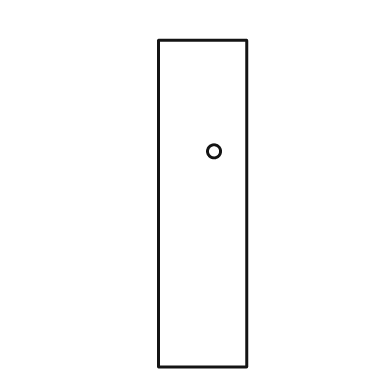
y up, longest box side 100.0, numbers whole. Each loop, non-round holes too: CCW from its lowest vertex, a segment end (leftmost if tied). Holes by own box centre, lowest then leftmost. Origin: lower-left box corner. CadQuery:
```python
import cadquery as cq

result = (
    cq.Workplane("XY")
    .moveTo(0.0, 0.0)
    .lineTo(27.0, 0.0)
    .lineTo(27.0, 100.0)
    .lineTo(0.0, 100.0)
    .close()
    .moveTo(17.0, 66.0)
    .circle(2.0)
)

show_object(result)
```